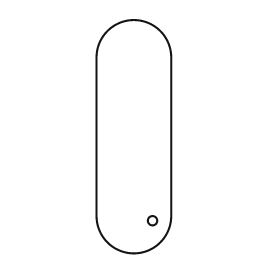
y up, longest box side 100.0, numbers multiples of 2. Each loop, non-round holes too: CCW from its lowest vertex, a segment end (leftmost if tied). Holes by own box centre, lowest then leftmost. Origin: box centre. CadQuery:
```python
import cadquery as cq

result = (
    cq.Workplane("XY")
    .moveTo(-16.0, -34.0)
    .threePointArc((0.0, -50.0), (16.0, -34.0))
    .lineTo(16.0, 34.0)
    .threePointArc((0.0, 50.0), (-16.0, 34.0))
    .close()
    .moveTo(8.0, -36.0)
    .circle(2.0)
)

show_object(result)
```